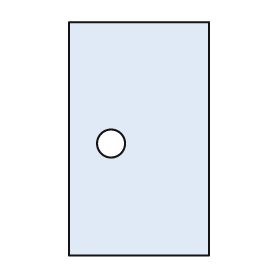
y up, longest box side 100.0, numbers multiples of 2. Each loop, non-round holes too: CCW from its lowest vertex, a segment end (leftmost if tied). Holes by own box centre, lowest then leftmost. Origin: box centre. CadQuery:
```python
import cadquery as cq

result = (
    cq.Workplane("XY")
    .moveTo(-30.0, -50.0)
    .lineTo(30.0, -50.0)
    .lineTo(30.0, 50.0)
    .lineTo(-30.0, 50.0)
    .close()
    .moveTo(-12.0, -2.0)
    .circle(6.0)
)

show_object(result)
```